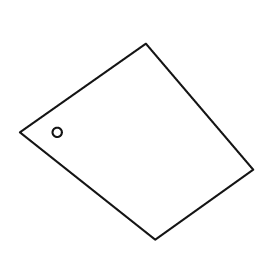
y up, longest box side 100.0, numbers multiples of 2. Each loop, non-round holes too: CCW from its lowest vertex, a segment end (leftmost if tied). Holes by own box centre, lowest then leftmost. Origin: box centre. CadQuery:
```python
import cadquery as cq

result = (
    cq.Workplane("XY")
    .moveTo(8.0, -42.0)
    .lineTo(50.0, -12.0)
    .lineTo(4.0, 42.0)
    .lineTo(-50.0, 4.0)
    .close()
    .moveTo(-34.0, 4.0)
    .circle(2.0)
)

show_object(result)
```